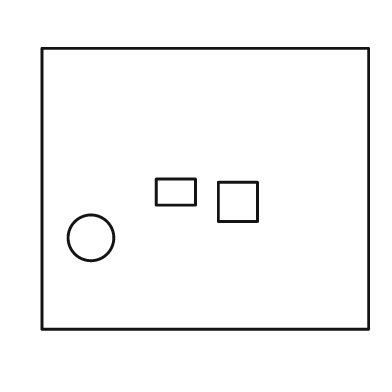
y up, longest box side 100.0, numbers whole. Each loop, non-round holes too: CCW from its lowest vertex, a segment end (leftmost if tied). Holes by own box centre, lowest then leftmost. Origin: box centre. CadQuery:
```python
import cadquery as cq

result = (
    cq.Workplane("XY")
    .moveTo(-50.0, -43.0)
    .lineTo(50.0, -43.0)
    .lineTo(50.0, 43.0)
    .lineTo(-50.0, 43.0)
    .close()
    .moveTo(-35.0, -15.0)
    .circle(7.0)
    .moveTo(4.0, -10.0)
    .lineTo(16.0, -10.0)
    .lineTo(16.0, 2.0)
    .lineTo(4.0, 2.0)
    .close()
    .moveTo(-15.0, -5.0)
    .lineTo(-3.0, -5.0)
    .lineTo(-3.0, 3.0)
    .lineTo(-15.0, 3.0)
    .close()
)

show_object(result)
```